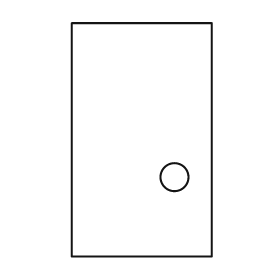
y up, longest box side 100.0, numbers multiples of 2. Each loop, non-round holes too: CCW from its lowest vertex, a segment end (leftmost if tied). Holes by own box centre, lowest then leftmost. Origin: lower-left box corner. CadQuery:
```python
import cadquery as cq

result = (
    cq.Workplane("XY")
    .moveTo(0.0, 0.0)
    .lineTo(60.0, 0.0)
    .lineTo(60.0, 100.0)
    .lineTo(0.0, 100.0)
    .close()
    .moveTo(44.0, 34.0)
    .circle(6.0)
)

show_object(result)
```